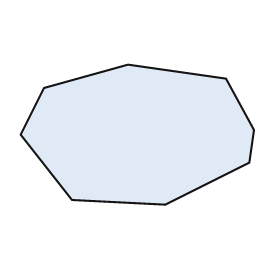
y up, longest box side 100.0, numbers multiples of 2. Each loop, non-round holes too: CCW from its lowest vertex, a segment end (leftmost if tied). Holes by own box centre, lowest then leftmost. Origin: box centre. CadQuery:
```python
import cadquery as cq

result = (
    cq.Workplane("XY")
    .moveTo(12.0, -30.0)
    .lineTo(48.0, -12.0)
    .lineTo(50.0, 2.0)
    .lineTo(38.0, 24.0)
    .lineTo(-4.0, 30.0)
    .lineTo(-40.0, 20.0)
    .lineTo(-50.0, 0.0)
    .lineTo(-28.0, -28.0)
    .close()
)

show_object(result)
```